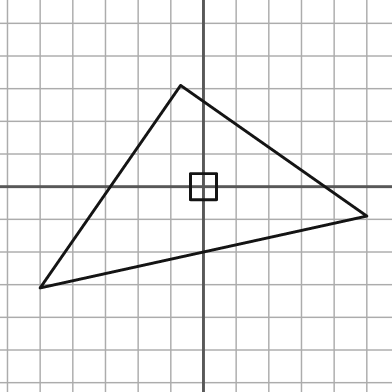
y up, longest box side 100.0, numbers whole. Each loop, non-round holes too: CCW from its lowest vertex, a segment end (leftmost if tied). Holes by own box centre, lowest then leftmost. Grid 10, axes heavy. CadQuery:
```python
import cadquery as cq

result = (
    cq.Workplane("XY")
    .moveTo(-50.0, -31.0)
    .lineTo(50.0, -9.0)
    .lineTo(-7.0, 31.0)
    .close()
    .moveTo(-4.0, -4.0)
    .lineTo(4.0, -4.0)
    .lineTo(4.0, 4.0)
    .lineTo(-4.0, 4.0)
    .close()
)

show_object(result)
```